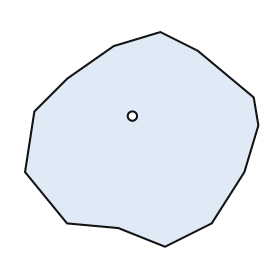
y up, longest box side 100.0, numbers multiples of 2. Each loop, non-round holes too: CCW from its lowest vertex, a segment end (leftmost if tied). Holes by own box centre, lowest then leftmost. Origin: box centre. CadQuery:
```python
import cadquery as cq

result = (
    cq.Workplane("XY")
    .moveTo(10.0, -46.0)
    .lineTo(30.0, -36.0)
    .lineTo(44.0, -14.0)
    .lineTo(50.0, 6.0)
    .lineTo(48.0, 18.0)
    .lineTo(24.0, 38.0)
    .lineTo(8.0, 46.0)
    .lineTo(-12.0, 40.0)
    .lineTo(-32.0, 26.0)
    .lineTo(-46.0, 12.0)
    .lineTo(-50.0, -14.0)
    .lineTo(-32.0, -36.0)
    .lineTo(-10.0, -38.0)
    .close()
    .moveTo(-4.0, 10.0)
    .circle(2.0)
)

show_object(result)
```